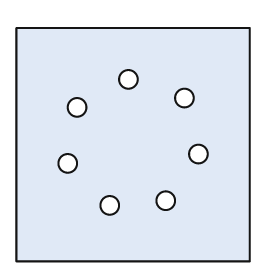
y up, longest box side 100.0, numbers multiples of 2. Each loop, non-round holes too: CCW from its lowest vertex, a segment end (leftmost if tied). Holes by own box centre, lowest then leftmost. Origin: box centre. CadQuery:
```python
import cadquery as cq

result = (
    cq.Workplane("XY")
    .moveTo(-50.0, -50.0)
    .lineTo(50.0, -50.0)
    .lineTo(50.0, 50.0)
    .lineTo(-50.0, 50.0)
    .close()
    .moveTo(-10.0, -26.0)
    .circle(4.0)
    .moveTo(14.0, -24.0)
    .circle(4.0)
    .moveTo(-28.0, -8.0)
    .circle(4.0)
    .moveTo(28.0, -4.0)
    .circle(4.0)
    .moveTo(-24.0, 16.0)
    .circle(4.0)
    .moveTo(22.0, 20.0)
    .circle(4.0)
    .moveTo(-2.0, 28.0)
    .circle(4.0)
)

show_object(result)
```